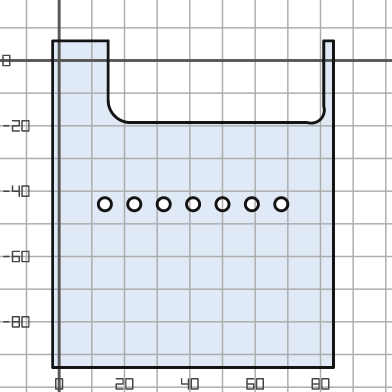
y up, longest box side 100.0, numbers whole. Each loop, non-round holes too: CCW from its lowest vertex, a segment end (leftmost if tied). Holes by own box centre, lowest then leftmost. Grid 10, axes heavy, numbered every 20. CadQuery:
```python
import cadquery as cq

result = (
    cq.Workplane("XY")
    .moveTo(-2.0, -94.0)
    .lineTo(84.0, -94.0)
    .lineTo(84.0, 6.0)
    .lineTo(81.0, 6.0)
    .lineTo(81.0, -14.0)
    .threePointArc((80.0, -18.0), (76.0, -19.0))
    .lineTo(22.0, -19.0)
    .threePointArc((17.0, -17.0), (15.0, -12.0))
    .lineTo(15.0, 6.0)
    .lineTo(-2.0, 6.0)
    .close()
    .moveTo(14.0, -44.0)
    .circle(2.0)
    .moveTo(23.0, -44.0)
    .circle(2.0)
    .moveTo(32.0, -44.0)
    .circle(2.0)
    .moveTo(41.0, -44.0)
    .circle(2.0)
    .moveTo(50.0, -44.0)
    .circle(2.0)
    .moveTo(59.0, -44.0)
    .circle(2.0)
    .moveTo(68.0, -44.0)
    .circle(2.0)
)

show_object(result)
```